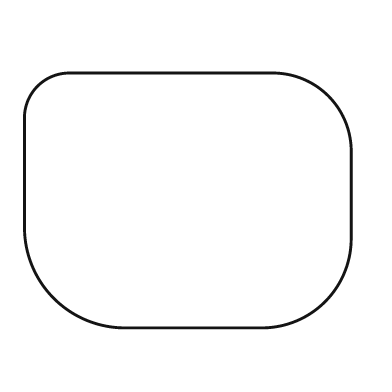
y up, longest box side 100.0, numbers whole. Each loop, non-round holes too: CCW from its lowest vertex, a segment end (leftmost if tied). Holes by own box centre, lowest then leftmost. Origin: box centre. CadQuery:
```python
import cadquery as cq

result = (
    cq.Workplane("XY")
    .moveTo(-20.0, -39.0)
    .lineTo(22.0, -39.0)
    .threePointArc((42.0, -31.0), (50.0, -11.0))
    .lineTo(50.0, 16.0)
    .threePointArc((43.0, 32.0), (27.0, 39.0))
    .lineTo(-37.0, 39.0)
    .threePointArc((-46.0, 35.0), (-50.0, 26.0))
    .lineTo(-50.0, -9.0)
    .threePointArc((-41.0, -30.0), (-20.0, -39.0))
    .close()
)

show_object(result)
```